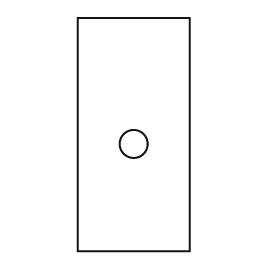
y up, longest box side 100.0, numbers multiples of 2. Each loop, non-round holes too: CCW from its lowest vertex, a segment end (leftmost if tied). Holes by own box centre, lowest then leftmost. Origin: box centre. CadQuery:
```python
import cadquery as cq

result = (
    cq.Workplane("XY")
    .moveTo(-24.0, -50.0)
    .lineTo(24.0, -50.0)
    .lineTo(24.0, 50.0)
    .lineTo(-24.0, 50.0)
    .close()
    .moveTo(0.0, -4.0)
    .circle(6.0)
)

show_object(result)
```